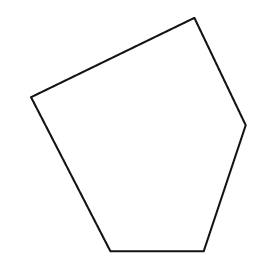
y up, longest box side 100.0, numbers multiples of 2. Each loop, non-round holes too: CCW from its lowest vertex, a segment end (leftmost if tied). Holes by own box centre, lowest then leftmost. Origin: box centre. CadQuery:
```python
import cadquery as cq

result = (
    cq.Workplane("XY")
    .moveTo(-12.0, -50.0)
    .lineTo(28.0, -50.0)
    .lineTo(46.0, 4.0)
    .lineTo(24.0, 50.0)
    .lineTo(-46.0, 16.0)
    .close()
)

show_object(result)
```